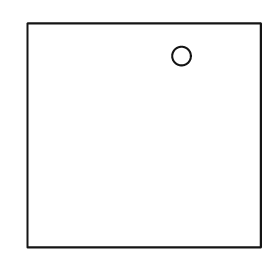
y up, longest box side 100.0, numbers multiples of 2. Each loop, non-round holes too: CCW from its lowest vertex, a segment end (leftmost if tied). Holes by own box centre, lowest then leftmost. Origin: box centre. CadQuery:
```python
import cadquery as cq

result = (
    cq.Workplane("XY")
    .moveTo(-50.0, -48.0)
    .lineTo(50.0, -48.0)
    .lineTo(50.0, 48.0)
    .lineTo(-50.0, 48.0)
    .close()
    .moveTo(16.0, 34.0)
    .circle(4.0)
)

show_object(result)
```